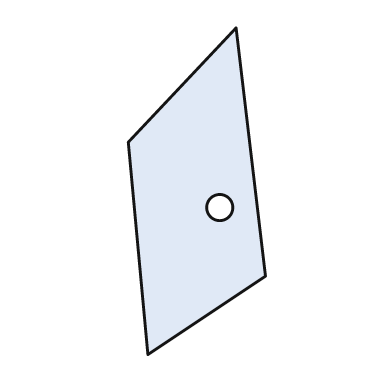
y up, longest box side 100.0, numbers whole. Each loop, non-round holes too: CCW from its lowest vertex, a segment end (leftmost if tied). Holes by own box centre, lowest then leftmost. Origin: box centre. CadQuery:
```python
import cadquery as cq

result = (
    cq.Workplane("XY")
    .moveTo(-15.0, -50.0)
    .lineTo(21.0, -26.0)
    .lineTo(12.0, 50.0)
    .lineTo(-21.0, 15.0)
    .close()
    .moveTo(7.0, -5.0)
    .circle(4.0)
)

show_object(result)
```